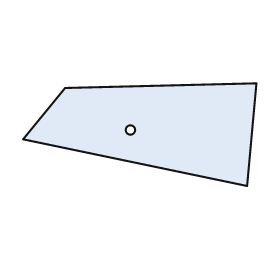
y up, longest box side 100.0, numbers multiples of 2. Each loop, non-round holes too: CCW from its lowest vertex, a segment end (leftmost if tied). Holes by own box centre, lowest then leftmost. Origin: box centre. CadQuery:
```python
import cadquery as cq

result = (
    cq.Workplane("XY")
    .moveTo(46.0, -22.0)
    .lineTo(50.0, 22.0)
    .lineTo(-32.0, 20.0)
    .lineTo(-50.0, -2.0)
    .close()
    .moveTo(-4.0, 2.0)
    .circle(2.0)
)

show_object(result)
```